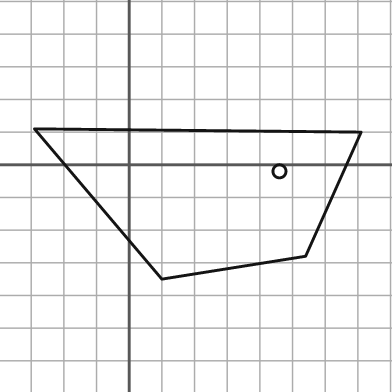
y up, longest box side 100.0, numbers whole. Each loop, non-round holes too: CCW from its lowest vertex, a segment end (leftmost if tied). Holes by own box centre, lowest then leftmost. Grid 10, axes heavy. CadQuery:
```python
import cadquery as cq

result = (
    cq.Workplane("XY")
    .moveTo(10.0, -35.0)
    .lineTo(54.0, -28.0)
    .lineTo(71.0, 10.0)
    .lineTo(-29.0, 11.0)
    .close()
    .moveTo(46.0, -2.0)
    .circle(2.0)
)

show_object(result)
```